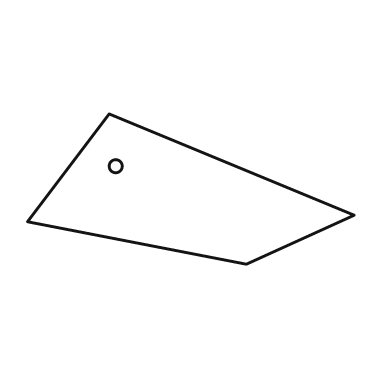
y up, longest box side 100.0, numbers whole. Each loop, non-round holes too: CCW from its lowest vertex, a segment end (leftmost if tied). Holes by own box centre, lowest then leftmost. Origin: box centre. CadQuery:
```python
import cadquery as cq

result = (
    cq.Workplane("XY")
    .moveTo(17.0, -23.0)
    .lineTo(50.0, -8.0)
    .lineTo(-25.0, 23.0)
    .lineTo(-50.0, -10.0)
    .close()
    .moveTo(-23.0, 7.0)
    .circle(2.0)
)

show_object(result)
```